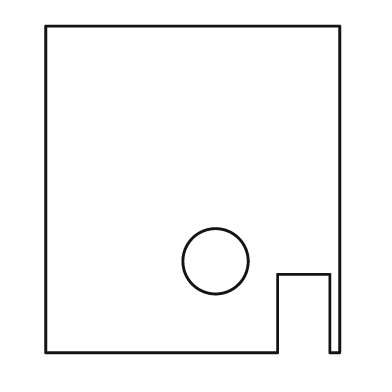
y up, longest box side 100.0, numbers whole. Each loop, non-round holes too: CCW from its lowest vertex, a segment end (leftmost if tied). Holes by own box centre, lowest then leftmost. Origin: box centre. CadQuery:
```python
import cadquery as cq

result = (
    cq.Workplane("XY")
    .moveTo(-45.0, -50.0)
    .lineTo(26.0, -50.0)
    .lineTo(26.0, -26.0)
    .lineTo(42.0, -26.0)
    .lineTo(42.0, -50.0)
    .lineTo(45.0, -50.0)
    .lineTo(45.0, 50.0)
    .lineTo(-45.0, 50.0)
    .close()
    .moveTo(7.0, -22.0)
    .circle(10.0)
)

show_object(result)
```